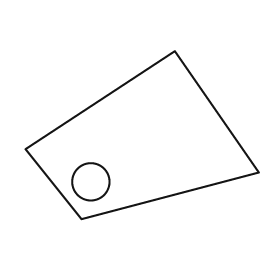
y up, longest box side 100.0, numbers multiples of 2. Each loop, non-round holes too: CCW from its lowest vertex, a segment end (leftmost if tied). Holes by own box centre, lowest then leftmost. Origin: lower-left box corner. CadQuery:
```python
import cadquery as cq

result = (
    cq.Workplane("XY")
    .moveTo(24.0, 0.0)
    .lineTo(100.0, 20.0)
    .lineTo(64.0, 72.0)
    .lineTo(0.0, 30.0)
    .close()
    .moveTo(28.0, 16.0)
    .circle(8.0)
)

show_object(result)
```